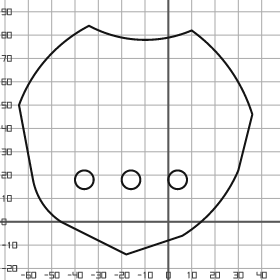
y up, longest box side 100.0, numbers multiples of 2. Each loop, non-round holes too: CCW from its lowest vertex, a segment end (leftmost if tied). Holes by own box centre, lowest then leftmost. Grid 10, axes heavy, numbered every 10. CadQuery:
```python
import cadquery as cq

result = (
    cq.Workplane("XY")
    .moveTo(-18.0, -14.0)
    .lineTo(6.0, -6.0)
    .threePointArc((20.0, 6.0), (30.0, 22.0))
    .lineTo(36.0, 46.0)
    .threePointArc((26.0, 66.0), (10.0, 82.0))
    .threePointArc((-12.0, 78.0), (-34.0, 84.0))
    .threePointArc((-52.0, 70.0), (-64.0, 50.0))
    .lineTo(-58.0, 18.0)
    .threePointArc((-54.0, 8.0), (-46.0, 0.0))
    .close()
    .moveTo(-36.0, 18.0)
    .circle(4.0)
    .moveTo(-16.0, 18.0)
    .circle(4.0)
    .moveTo(4.0, 18.0)
    .circle(4.0)
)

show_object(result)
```